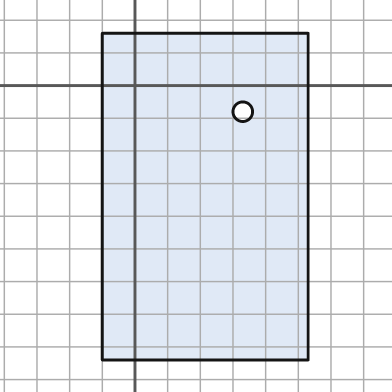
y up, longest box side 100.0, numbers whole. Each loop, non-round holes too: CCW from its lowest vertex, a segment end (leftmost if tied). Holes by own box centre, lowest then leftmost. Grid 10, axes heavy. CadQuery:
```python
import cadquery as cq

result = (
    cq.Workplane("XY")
    .moveTo(-10.0, -84.0)
    .lineTo(53.0, -84.0)
    .lineTo(53.0, 16.0)
    .lineTo(-10.0, 16.0)
    .close()
    .moveTo(33.0, -8.0)
    .circle(3.0)
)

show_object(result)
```